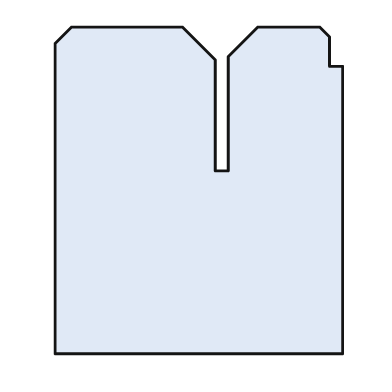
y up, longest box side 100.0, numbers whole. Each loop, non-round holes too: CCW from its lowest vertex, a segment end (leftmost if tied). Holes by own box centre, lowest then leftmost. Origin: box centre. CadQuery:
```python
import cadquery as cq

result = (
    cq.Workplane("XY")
    .moveTo(-44.0, -50.0)
    .lineTo(44.0, -50.0)
    .lineTo(44.0, 38.0)
    .lineTo(40.0, 38.0)
    .lineTo(40.0, 47.0)
    .lineTo(37.0, 50.0)
    .lineTo(18.0, 50.0)
    .lineTo(9.0, 41.0)
    .lineTo(9.0, 6.0)
    .lineTo(5.0, 6.0)
    .lineTo(5.0, 40.0)
    .lineTo(-5.0, 50.0)
    .lineTo(-39.0, 50.0)
    .lineTo(-44.0, 45.0)
    .close()
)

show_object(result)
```